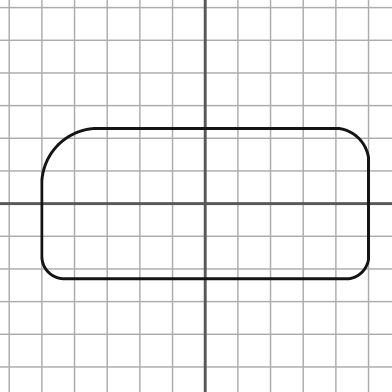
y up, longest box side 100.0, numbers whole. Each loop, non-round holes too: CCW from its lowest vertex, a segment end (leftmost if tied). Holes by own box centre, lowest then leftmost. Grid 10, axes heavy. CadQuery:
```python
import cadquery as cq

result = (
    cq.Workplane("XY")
    .moveTo(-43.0, -23.0)
    .lineTo(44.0, -23.0)
    .threePointArc((48.0, -21.0), (50.0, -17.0))
    .lineTo(50.0, 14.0)
    .threePointArc((47.0, 20.0), (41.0, 23.0))
    .lineTo(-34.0, 23.0)
    .threePointArc((-45.0, 18.0), (-50.0, 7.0))
    .lineTo(-50.0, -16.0)
    .threePointArc((-48.0, -21.0), (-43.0, -23.0))
    .close()
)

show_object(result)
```